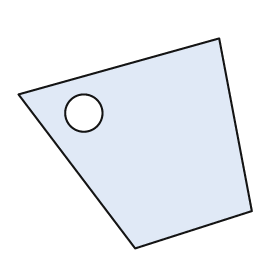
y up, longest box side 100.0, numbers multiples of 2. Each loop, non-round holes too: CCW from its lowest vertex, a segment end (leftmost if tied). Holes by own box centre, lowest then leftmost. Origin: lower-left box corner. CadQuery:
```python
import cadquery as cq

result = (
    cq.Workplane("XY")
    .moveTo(50.0, 0.0)
    .lineTo(100.0, 16.0)
    .lineTo(86.0, 90.0)
    .lineTo(0.0, 66.0)
    .close()
    .moveTo(28.0, 58.0)
    .circle(8.0)
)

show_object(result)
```